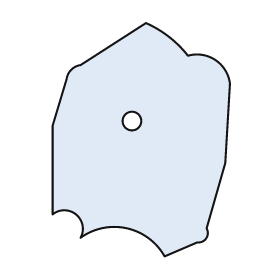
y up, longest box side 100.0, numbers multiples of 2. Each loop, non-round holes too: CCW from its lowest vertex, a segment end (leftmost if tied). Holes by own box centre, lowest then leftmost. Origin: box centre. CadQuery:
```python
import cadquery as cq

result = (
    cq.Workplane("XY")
    .moveTo(10.0, -50.0)
    .lineTo(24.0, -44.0)
    .threePointArc((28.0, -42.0), (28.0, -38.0))
    .lineTo(36.0, -10.0)
    .lineTo(38.0, 24.0)
    .threePointArc((32.0, 34.0), (20.0, 36.0))
    .threePointArc((12.0, 44.0), (2.0, 50.0))
    .lineTo(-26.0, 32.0)
    .threePointArc((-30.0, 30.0), (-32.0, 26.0))
    .lineTo(-38.0, 6.0)
    .lineTo(-38.0, -32.0)
    .threePointArc((-28.0, -32.0), (-26.0, -42.0))
    .threePointArc((-6.0, -38.0), (10.0, -50.0))
    .close()
    .moveTo(-4.0, 8.0)
    .circle(4.0)
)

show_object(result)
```